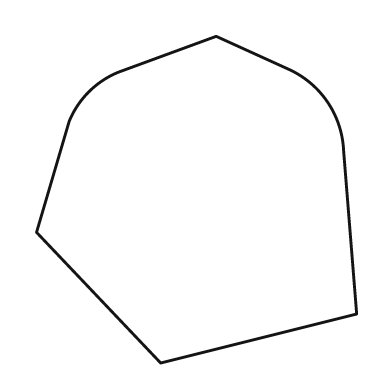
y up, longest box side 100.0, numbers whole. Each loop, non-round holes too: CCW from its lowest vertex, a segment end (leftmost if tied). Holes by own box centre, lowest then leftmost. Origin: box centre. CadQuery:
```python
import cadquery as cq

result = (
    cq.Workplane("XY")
    .moveTo(-11.0, -50.0)
    .lineTo(49.0, -35.0)
    .lineTo(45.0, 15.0)
    .threePointArc((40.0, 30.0), (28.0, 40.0))
    .lineTo(6.0, 50.0)
    .lineTo(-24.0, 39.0)
    .threePointArc((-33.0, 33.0), (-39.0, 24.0))
    .lineTo(-49.0, -10.0)
    .close()
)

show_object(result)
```